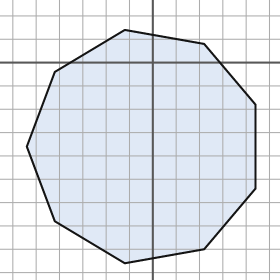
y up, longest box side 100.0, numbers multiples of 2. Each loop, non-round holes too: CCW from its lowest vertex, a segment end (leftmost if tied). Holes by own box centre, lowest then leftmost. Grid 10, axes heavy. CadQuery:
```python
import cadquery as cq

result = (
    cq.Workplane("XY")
    .moveTo(-12.0, -86.0)
    .lineTo(22.0, -80.0)
    .lineTo(44.0, -54.0)
    .lineTo(44.0, -18.0)
    .lineTo(22.0, 8.0)
    .lineTo(-12.0, 14.0)
    .lineTo(-42.0, -4.0)
    .lineTo(-54.0, -36.0)
    .lineTo(-42.0, -68.0)
    .close()
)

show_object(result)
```